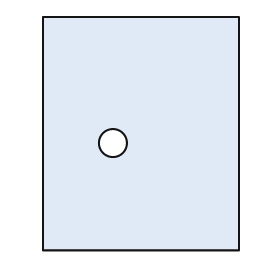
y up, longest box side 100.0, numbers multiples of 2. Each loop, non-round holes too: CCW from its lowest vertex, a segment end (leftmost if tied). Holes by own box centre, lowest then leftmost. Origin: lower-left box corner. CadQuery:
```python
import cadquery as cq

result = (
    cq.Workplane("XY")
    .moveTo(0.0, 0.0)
    .lineTo(84.0, 0.0)
    .lineTo(84.0, 100.0)
    .lineTo(0.0, 100.0)
    .close()
    .moveTo(30.0, 46.0)
    .circle(6.0)
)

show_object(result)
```